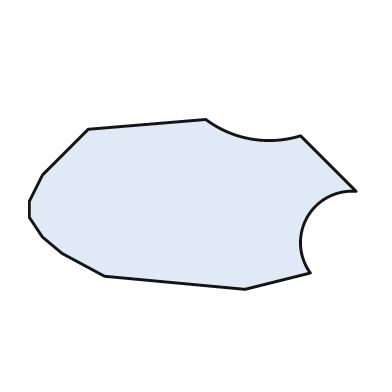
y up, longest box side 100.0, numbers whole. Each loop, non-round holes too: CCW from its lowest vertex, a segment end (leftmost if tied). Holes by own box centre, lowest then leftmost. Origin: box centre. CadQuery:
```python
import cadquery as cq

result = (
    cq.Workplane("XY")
    .moveTo(16.0, -26.0)
    .lineTo(36.0, -21.0)
    .threePointArc((35.0, -4.0), (50.0, 4.0))
    .lineTo(33.0, 21.0)
    .threePointArc((18.0, 20.0), (4.0, 26.0))
    .lineTo(-32.0, 23.0)
    .lineTo(-46.0, 9.0)
    .lineTo(-50.0, 1.0)
    .lineTo(-50.0, -4.0)
    .lineTo(-46.0, -10.0)
    .lineTo(-40.0, -15.0)
    .lineTo(-27.0, -22.0)
    .close()
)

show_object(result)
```